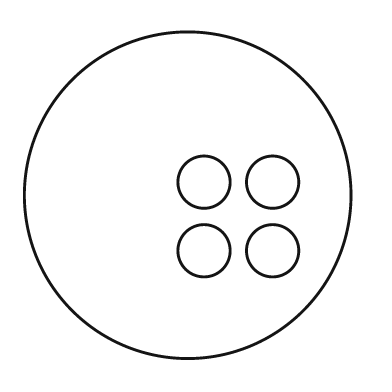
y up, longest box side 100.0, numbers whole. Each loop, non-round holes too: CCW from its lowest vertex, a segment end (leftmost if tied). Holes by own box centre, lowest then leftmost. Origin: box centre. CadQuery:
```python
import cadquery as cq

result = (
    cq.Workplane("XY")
    .moveTo(0.0, 0.0)
    .circle(50.0)
    .moveTo(5.0, -17.0)
    .circle(8.0)
    .moveTo(26.0, -17.0)
    .circle(8.0)
    .moveTo(5.0, 4.0)
    .circle(8.0)
    .moveTo(26.0, 4.0)
    .circle(8.0)
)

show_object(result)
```